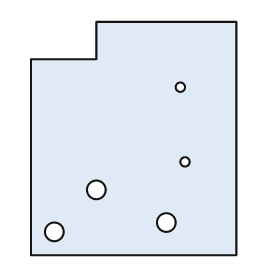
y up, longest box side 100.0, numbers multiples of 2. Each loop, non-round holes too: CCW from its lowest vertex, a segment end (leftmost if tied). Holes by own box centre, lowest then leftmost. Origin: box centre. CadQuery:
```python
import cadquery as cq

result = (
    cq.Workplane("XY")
    .moveTo(-44.0, -50.0)
    .lineTo(44.0, -50.0)
    .lineTo(44.0, 50.0)
    .lineTo(-16.0, 50.0)
    .lineTo(-16.0, 34.0)
    .lineTo(-44.0, 34.0)
    .close()
    .moveTo(-34.0, -40.0)
    .circle(4.0)
    .moveTo(14.0, -36.0)
    .circle(4.0)
    .moveTo(-16.0, -22.0)
    .circle(4.0)
    .moveTo(22.0, -10.0)
    .circle(2.0)
    .moveTo(20.0, 22.0)
    .circle(2.0)
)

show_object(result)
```